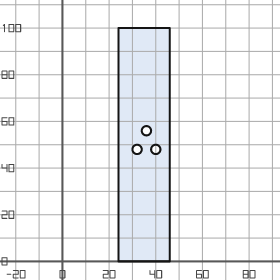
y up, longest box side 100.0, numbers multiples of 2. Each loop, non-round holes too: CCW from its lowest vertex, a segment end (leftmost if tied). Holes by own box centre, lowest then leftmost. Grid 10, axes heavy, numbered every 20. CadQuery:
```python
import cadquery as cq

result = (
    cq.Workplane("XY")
    .moveTo(24.0, 0.0)
    .lineTo(46.0, 0.0)
    .lineTo(46.0, 100.0)
    .lineTo(24.0, 100.0)
    .close()
    .moveTo(32.0, 48.0)
    .circle(2.0)
    .moveTo(40.0, 48.0)
    .circle(2.0)
    .moveTo(36.0, 56.0)
    .circle(2.0)
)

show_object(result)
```